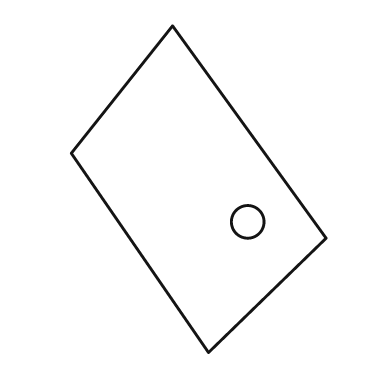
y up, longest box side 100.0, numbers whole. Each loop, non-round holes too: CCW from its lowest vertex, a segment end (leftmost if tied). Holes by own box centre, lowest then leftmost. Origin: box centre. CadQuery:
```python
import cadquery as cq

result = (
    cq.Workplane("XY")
    .moveTo(3.0, -50.0)
    .lineTo(39.0, -15.0)
    .lineTo(-8.0, 50.0)
    .lineTo(-39.0, 11.0)
    .close()
    .moveTo(15.0, -10.0)
    .circle(5.0)
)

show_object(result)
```